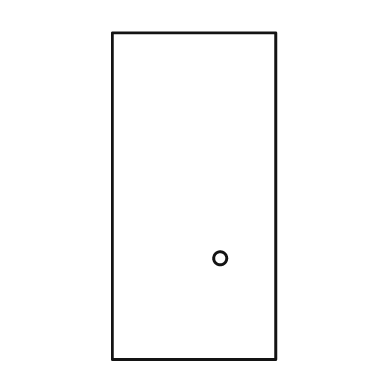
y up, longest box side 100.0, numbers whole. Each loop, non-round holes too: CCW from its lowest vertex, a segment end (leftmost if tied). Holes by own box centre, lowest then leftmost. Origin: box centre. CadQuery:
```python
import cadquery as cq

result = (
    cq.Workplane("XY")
    .moveTo(-25.0, -50.0)
    .lineTo(25.0, -50.0)
    .lineTo(25.0, 50.0)
    .lineTo(-25.0, 50.0)
    .close()
    .moveTo(8.0, -19.0)
    .circle(2.0)
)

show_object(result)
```